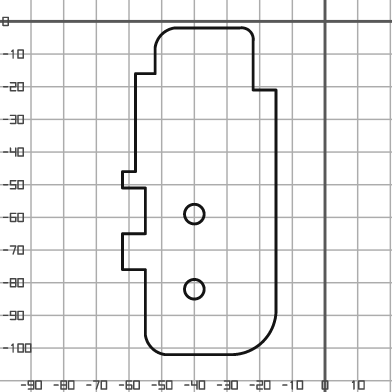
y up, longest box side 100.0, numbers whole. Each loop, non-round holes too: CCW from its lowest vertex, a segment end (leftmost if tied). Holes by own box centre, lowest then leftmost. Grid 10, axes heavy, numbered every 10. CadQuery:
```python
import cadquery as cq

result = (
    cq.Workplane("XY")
    .moveTo(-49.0, -102.0)
    .lineTo(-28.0, -102.0)
    .threePointArc((-19.0, -98.0), (-15.0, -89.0))
    .lineTo(-15.0, -21.0)
    .lineTo(-22.0, -21.0)
    .lineTo(-22.0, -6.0)
    .threePointArc((-23.0, -3.0), (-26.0, -2.0))
    .lineTo(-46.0, -2.0)
    .threePointArc((-50.0, -4.0), (-52.0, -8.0))
    .lineTo(-52.0, -16.0)
    .lineTo(-58.0, -16.0)
    .lineTo(-58.0, -46.0)
    .lineTo(-62.0, -46.0)
    .lineTo(-62.0, -51.0)
    .lineTo(-55.0, -51.0)
    .lineTo(-55.0, -65.0)
    .lineTo(-62.0, -65.0)
    .lineTo(-62.0, -76.0)
    .lineTo(-55.0, -76.0)
    .lineTo(-55.0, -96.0)
    .threePointArc((-53.0, -100.0), (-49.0, -102.0))
    .close()
    .moveTo(-40.0, -82.0)
    .circle(3.0)
    .moveTo(-40.0, -59.0)
    .circle(3.0)
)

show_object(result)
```